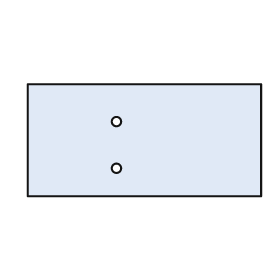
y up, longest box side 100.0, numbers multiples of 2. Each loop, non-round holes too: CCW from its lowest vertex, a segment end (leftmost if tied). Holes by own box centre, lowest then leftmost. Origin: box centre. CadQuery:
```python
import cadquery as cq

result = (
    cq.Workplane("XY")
    .moveTo(-50.0, -24.0)
    .lineTo(50.0, -24.0)
    .lineTo(50.0, 24.0)
    .lineTo(-50.0, 24.0)
    .close()
    .moveTo(-12.0, -12.0)
    .circle(2.0)
    .moveTo(-12.0, 8.0)
    .circle(2.0)
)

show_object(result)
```